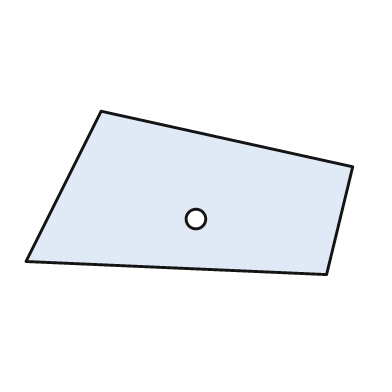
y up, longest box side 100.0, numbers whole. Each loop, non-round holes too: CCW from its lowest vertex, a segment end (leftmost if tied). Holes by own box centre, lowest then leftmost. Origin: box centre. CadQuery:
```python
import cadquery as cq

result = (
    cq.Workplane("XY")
    .moveTo(42.0, -25.0)
    .lineTo(50.0, 8.0)
    .lineTo(-27.0, 25.0)
    .lineTo(-50.0, -21.0)
    .close()
    .moveTo(2.0, -8.0)
    .circle(3.0)
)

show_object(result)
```